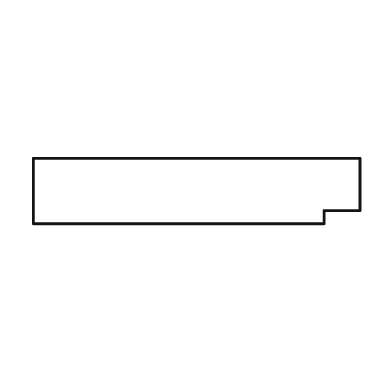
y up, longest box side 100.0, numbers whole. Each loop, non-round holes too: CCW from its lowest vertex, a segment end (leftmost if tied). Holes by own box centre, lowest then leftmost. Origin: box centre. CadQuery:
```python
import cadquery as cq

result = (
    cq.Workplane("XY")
    .moveTo(-50.0, -10.0)
    .lineTo(39.0, -10.0)
    .lineTo(39.0, -6.0)
    .lineTo(50.0, -6.0)
    .lineTo(50.0, 10.0)
    .lineTo(-50.0, 10.0)
    .close()
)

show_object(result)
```